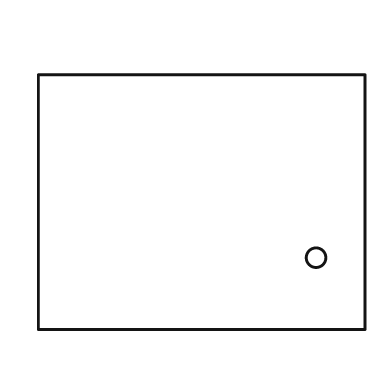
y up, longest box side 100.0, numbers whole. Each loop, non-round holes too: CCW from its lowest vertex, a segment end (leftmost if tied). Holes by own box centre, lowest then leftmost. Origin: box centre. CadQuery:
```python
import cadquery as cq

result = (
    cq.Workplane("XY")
    .moveTo(-50.0, -39.0)
    .lineTo(50.0, -39.0)
    .lineTo(50.0, 39.0)
    .lineTo(-50.0, 39.0)
    .close()
    .moveTo(35.0, -17.0)
    .circle(3.0)
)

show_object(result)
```